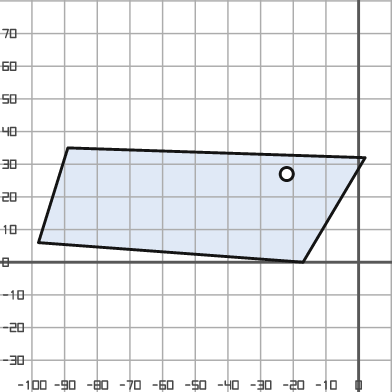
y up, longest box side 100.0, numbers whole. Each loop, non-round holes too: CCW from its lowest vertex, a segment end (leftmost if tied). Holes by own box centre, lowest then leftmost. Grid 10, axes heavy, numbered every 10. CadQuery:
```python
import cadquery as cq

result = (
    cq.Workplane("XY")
    .moveTo(-17.0, 0.0)
    .lineTo(2.0, 32.0)
    .lineTo(-89.0, 35.0)
    .lineTo(-98.0, 6.0)
    .close()
    .moveTo(-22.0, 27.0)
    .circle(2.0)
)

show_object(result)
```